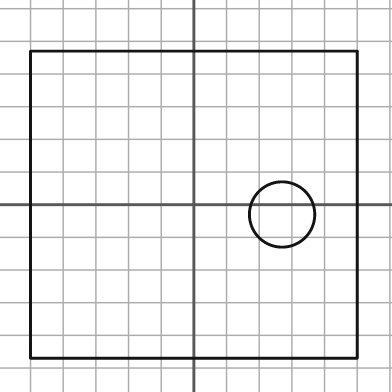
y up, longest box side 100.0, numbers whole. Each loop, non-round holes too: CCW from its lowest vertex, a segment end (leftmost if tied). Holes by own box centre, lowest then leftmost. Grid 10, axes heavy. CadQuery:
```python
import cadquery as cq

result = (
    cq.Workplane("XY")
    .moveTo(-50.0, -47.0)
    .lineTo(50.0, -47.0)
    .lineTo(50.0, 47.0)
    .lineTo(-50.0, 47.0)
    .close()
    .moveTo(27.0, -3.0)
    .circle(10.0)
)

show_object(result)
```